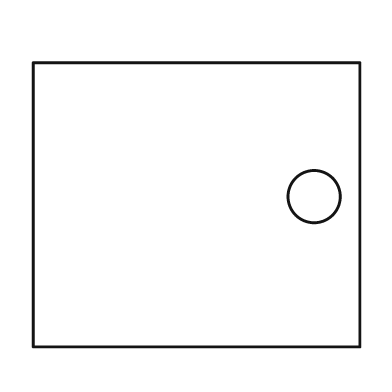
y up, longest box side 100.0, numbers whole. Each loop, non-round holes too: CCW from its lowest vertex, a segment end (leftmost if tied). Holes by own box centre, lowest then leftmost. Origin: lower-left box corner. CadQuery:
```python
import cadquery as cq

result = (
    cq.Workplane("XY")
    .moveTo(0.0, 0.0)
    .lineTo(100.0, 0.0)
    .lineTo(100.0, 87.0)
    .lineTo(0.0, 87.0)
    .close()
    .moveTo(86.0, 46.0)
    .circle(8.0)
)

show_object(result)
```